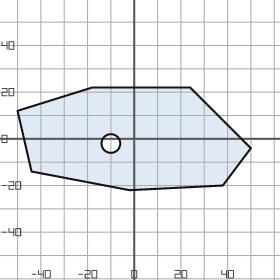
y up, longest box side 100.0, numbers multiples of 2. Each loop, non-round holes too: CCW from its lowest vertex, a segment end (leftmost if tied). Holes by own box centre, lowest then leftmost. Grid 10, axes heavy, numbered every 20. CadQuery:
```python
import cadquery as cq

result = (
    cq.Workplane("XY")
    .moveTo(-2.0, -22.0)
    .lineTo(38.0, -20.0)
    .lineTo(50.0, -4.0)
    .lineTo(24.0, 22.0)
    .lineTo(-18.0, 22.0)
    .lineTo(-50.0, 12.0)
    .lineTo(-44.0, -14.0)
    .close()
    .moveTo(-10.0, -2.0)
    .circle(4.0)
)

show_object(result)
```